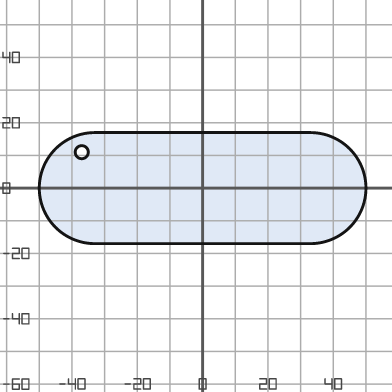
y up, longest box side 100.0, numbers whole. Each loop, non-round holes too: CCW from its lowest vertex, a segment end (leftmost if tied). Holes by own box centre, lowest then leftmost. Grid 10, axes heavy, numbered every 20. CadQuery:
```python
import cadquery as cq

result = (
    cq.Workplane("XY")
    .moveTo(-33.0, -17.0)
    .lineTo(33.0, -17.0)
    .threePointArc((50.0, 0.0), (33.0, 17.0))
    .lineTo(-33.0, 17.0)
    .threePointArc((-50.0, 0.0), (-33.0, -17.0))
    .close()
    .moveTo(-37.0, 11.0)
    .circle(2.0)
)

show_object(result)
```